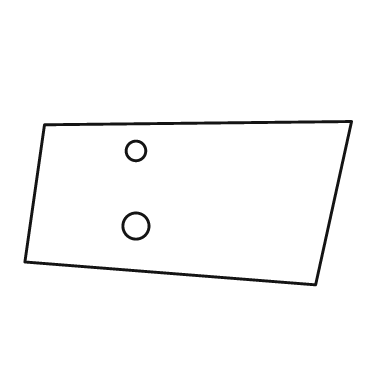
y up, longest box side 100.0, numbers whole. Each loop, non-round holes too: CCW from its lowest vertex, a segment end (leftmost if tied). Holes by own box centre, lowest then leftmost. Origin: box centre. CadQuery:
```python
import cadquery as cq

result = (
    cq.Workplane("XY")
    .moveTo(39.0, -25.0)
    .lineTo(50.0, 25.0)
    .lineTo(-44.0, 24.0)
    .lineTo(-50.0, -18.0)
    .close()
    .moveTo(-16.0, -7.0)
    .circle(4.0)
    .moveTo(-16.0, 16.0)
    .circle(3.0)
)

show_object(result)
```